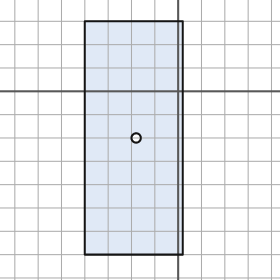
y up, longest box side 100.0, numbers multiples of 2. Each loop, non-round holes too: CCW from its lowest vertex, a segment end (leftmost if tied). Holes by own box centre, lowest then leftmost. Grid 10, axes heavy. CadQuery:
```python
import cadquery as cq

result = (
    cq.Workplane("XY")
    .moveTo(-40.0, -70.0)
    .lineTo(2.0, -70.0)
    .lineTo(2.0, 30.0)
    .lineTo(-40.0, 30.0)
    .close()
    .moveTo(-18.0, -20.0)
    .circle(2.0)
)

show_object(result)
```